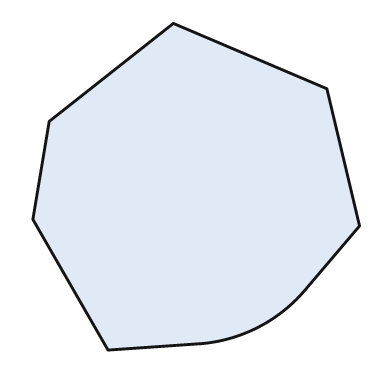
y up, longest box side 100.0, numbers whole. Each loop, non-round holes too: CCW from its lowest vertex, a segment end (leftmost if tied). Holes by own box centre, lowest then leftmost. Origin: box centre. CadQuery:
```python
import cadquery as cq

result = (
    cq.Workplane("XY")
    .moveTo(-27.0, -50.0)
    .lineTo(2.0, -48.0)
    .threePointArc((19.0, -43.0), (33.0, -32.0))
    .lineTo(50.0, -12.0)
    .lineTo(40.0, 30.0)
    .lineTo(-7.0, 50.0)
    .lineTo(-45.0, 20.0)
    .lineTo(-50.0, -10.0)
    .close()
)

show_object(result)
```